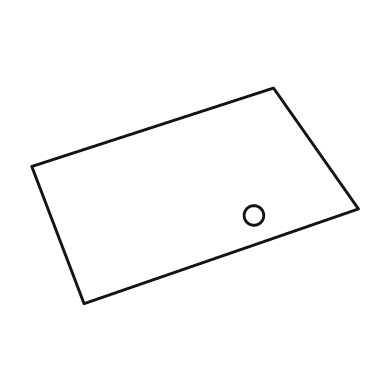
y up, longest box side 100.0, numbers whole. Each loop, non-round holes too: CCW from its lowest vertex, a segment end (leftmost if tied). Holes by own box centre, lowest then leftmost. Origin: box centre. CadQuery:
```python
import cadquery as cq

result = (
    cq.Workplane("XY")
    .moveTo(-34.0, -33.0)
    .lineTo(50.0, -4.0)
    .lineTo(24.0, 33.0)
    .lineTo(-50.0, 9.0)
    .close()
    .moveTo(18.0, -6.0)
    .circle(3.0)
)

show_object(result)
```